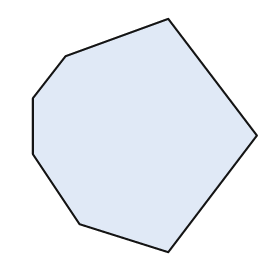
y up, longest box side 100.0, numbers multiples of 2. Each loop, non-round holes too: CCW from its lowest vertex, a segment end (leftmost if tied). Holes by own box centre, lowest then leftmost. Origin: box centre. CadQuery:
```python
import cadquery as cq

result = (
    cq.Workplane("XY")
    .moveTo(10.0, -50.0)
    .lineTo(48.0, 0.0)
    .lineTo(10.0, 50.0)
    .lineTo(-34.0, 34.0)
    .lineTo(-48.0, 16.0)
    .lineTo(-48.0, -8.0)
    .lineTo(-28.0, -38.0)
    .close()
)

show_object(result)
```